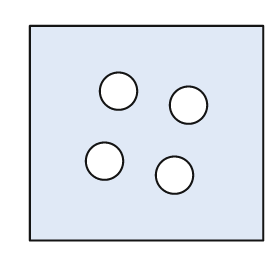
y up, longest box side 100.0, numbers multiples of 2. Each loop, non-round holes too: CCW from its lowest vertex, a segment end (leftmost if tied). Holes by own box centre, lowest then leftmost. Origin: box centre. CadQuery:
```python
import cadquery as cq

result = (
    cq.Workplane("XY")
    .moveTo(-50.0, -46.0)
    .lineTo(50.0, -46.0)
    .lineTo(50.0, 46.0)
    .lineTo(-50.0, 46.0)
    .close()
    .moveTo(12.0, -18.0)
    .circle(8.0)
    .moveTo(-18.0, -12.0)
    .circle(8.0)
    .moveTo(18.0, 12.0)
    .circle(8.0)
    .moveTo(-12.0, 18.0)
    .circle(8.0)
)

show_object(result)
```